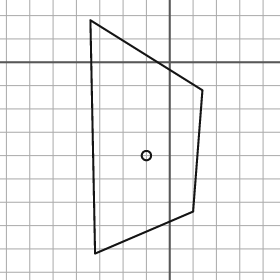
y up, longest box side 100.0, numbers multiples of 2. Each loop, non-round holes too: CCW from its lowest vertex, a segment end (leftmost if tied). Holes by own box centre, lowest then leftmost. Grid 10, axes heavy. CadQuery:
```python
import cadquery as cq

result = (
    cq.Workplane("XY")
    .moveTo(-32.0, -82.0)
    .lineTo(10.0, -64.0)
    .lineTo(14.0, -12.0)
    .lineTo(-34.0, 18.0)
    .close()
    .moveTo(-10.0, -40.0)
    .circle(2.0)
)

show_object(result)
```